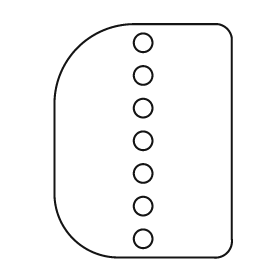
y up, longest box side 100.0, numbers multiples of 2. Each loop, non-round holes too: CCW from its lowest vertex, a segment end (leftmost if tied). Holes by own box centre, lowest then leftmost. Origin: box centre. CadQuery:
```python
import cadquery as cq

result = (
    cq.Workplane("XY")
    .moveTo(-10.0, -50.0)
    .lineTo(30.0, -50.0)
    .threePointArc((36.0, -48.0), (38.0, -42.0))
    .lineTo(38.0, 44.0)
    .threePointArc((36.0, 48.0), (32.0, 50.0))
    .lineTo(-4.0, 50.0)
    .threePointArc((-28.0, 40.0), (-38.0, 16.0))
    .lineTo(-38.0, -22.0)
    .threePointArc((-30.0, -42.0), (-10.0, -50.0))
    .close()
    .moveTo(0.0, -42.0)
    .circle(4.0)
    .moveTo(0.0, -28.0)
    .circle(4.0)
    .moveTo(0.0, -14.0)
    .circle(4.0)
    .moveTo(0.0, 0.0)
    .circle(4.0)
    .moveTo(0.0, 14.0)
    .circle(4.0)
    .moveTo(0.0, 28.0)
    .circle(4.0)
    .moveTo(0.0, 42.0)
    .circle(4.0)
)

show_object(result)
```